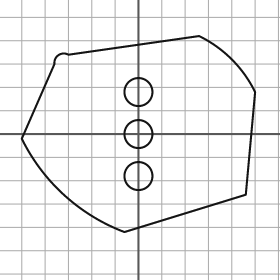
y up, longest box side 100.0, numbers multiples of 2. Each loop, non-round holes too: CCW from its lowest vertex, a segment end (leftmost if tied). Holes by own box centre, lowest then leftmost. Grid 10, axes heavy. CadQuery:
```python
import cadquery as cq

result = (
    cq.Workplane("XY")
    .moveTo(-6.0, -42.0)
    .lineTo(46.0, -26.0)
    .lineTo(50.0, 18.0)
    .threePointArc((40.0, 32.0), (26.0, 42.0))
    .lineTo(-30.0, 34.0)
    .threePointArc((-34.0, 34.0), (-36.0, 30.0))
    .lineTo(-50.0, -2.0)
    .threePointArc((-32.0, -26.0), (-6.0, -42.0))
    .close()
    .moveTo(0.0, -18.0)
    .circle(6.0)
    .moveTo(0.0, 0.0)
    .circle(6.0)
    .moveTo(0.0, 18.0)
    .circle(6.0)
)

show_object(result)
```